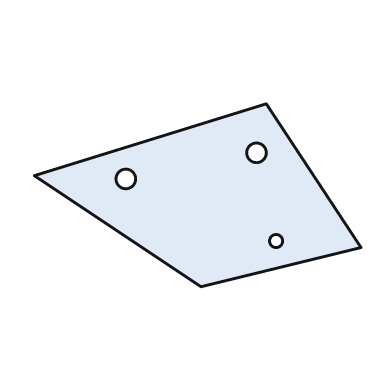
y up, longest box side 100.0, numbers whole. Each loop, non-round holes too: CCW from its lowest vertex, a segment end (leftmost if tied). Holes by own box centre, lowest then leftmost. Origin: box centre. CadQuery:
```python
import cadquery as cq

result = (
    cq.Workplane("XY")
    .moveTo(1.0, -28.0)
    .lineTo(50.0, -16.0)
    .lineTo(21.0, 28.0)
    .lineTo(-50.0, 6.0)
    .close()
    .moveTo(24.0, -14.0)
    .circle(2.0)
    .moveTo(-22.0, 5.0)
    .circle(3.0)
    .moveTo(18.0, 13.0)
    .circle(3.0)
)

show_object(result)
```